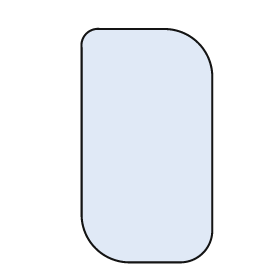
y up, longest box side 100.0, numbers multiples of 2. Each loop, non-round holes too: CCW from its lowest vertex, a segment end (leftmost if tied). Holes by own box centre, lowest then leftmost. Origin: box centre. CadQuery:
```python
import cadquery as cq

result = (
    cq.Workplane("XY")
    .moveTo(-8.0, -50.0)
    .lineTo(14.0, -50.0)
    .threePointArc((24.0, -46.0), (28.0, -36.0))
    .lineTo(28.0, 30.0)
    .threePointArc((22.0, 44.0), (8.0, 50.0))
    .lineTo(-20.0, 50.0)
    .threePointArc((-26.0, 48.0), (-28.0, 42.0))
    .lineTo(-28.0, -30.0)
    .threePointArc((-22.0, -44.0), (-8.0, -50.0))
    .close()
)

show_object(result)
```